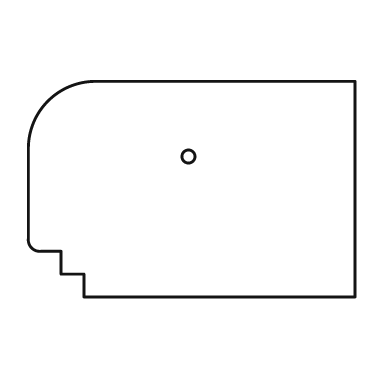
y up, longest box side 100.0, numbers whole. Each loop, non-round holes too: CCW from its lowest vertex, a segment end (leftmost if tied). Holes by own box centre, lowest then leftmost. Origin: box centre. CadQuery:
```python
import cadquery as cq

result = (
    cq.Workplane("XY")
    .moveTo(-33.0, -33.0)
    .lineTo(50.0, -33.0)
    .lineTo(50.0, 33.0)
    .lineTo(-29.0, 33.0)
    .threePointArc((-44.0, 27.0), (-50.0, 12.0))
    .lineTo(-50.0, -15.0)
    .threePointArc((-49.0, -18.0), (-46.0, -19.0))
    .lineTo(-40.0, -19.0)
    .lineTo(-40.0, -26.0)
    .lineTo(-33.0, -26.0)
    .close()
    .moveTo(-1.0, 10.0)
    .circle(2.0)
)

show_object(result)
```